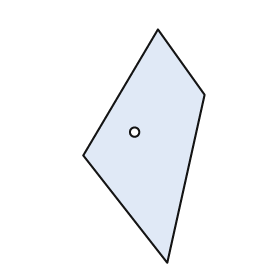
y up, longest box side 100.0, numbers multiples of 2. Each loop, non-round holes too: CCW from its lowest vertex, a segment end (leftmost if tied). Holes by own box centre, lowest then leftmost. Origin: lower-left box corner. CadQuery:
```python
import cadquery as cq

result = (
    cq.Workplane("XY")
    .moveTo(36.0, 0.0)
    .lineTo(52.0, 72.0)
    .lineTo(32.0, 100.0)
    .lineTo(0.0, 46.0)
    .close()
    .moveTo(22.0, 56.0)
    .circle(2.0)
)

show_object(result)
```